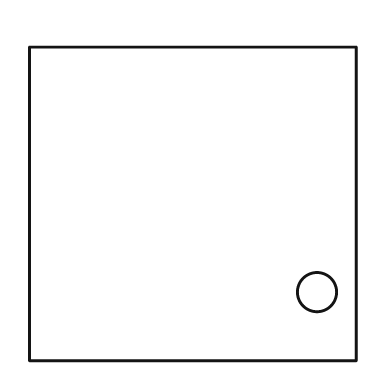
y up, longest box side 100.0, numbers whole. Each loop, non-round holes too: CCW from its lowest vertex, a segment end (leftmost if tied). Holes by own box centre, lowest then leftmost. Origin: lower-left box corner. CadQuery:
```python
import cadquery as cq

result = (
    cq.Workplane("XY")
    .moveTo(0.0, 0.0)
    .lineTo(100.0, 0.0)
    .lineTo(100.0, 96.0)
    .lineTo(0.0, 96.0)
    .close()
    .moveTo(88.0, 21.0)
    .circle(6.0)
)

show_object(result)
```